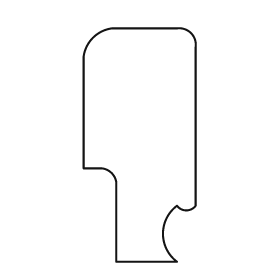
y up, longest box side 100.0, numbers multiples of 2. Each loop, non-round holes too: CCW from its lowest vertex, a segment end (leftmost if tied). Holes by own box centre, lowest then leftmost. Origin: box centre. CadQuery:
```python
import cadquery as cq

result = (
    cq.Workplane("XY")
    .moveTo(-10.0, -50.0)
    .lineTo(16.0, -50.0)
    .threePointArc((10.0, -38.0), (16.0, -26.0))
    .threePointArc((20.0, -28.0), (24.0, -26.0))
    .lineTo(24.0, 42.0)
    .threePointArc((22.0, 48.0), (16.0, 50.0))
    .lineTo(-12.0, 50.0)
    .threePointArc((-20.0, 46.0), (-24.0, 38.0))
    .lineTo(-24.0, -10.0)
    .lineTo(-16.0, -10.0)
    .threePointArc((-12.0, -12.0), (-10.0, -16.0))
    .close()
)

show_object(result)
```